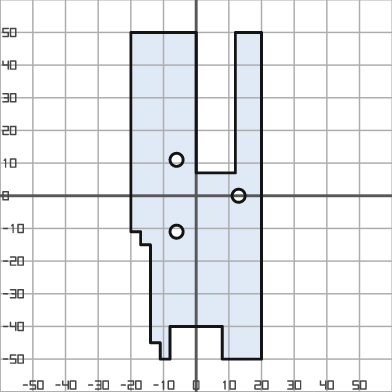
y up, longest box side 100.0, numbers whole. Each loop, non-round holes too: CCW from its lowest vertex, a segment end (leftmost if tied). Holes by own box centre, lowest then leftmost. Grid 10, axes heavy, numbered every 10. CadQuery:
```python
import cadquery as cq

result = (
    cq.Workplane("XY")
    .moveTo(-11.0, -50.0)
    .lineTo(-8.0, -50.0)
    .lineTo(-8.0, -40.0)
    .lineTo(8.0, -40.0)
    .lineTo(8.0, -50.0)
    .lineTo(20.0, -50.0)
    .lineTo(20.0, 50.0)
    .lineTo(12.0, 50.0)
    .lineTo(12.0, 7.0)
    .lineTo(0.0, 7.0)
    .lineTo(0.0, 50.0)
    .lineTo(-20.0, 50.0)
    .lineTo(-20.0, -11.0)
    .lineTo(-17.0, -11.0)
    .lineTo(-17.0, -15.0)
    .lineTo(-14.0, -15.0)
    .lineTo(-14.0, -45.0)
    .lineTo(-11.0, -45.0)
    .close()
    .moveTo(-6.0, -11.0)
    .circle(2.0)
    .moveTo(13.0, 0.0)
    .circle(2.0)
    .moveTo(-6.0, 11.0)
    .circle(2.0)
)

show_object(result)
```